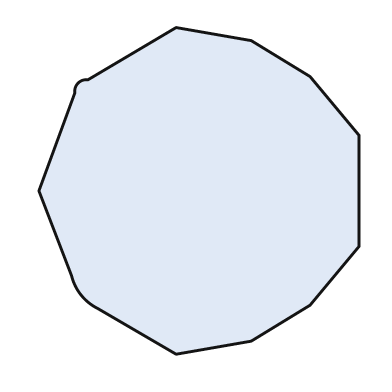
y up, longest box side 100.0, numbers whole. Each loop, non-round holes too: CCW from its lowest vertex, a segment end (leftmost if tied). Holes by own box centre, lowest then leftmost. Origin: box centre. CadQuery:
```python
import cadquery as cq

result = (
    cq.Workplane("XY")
    .moveTo(-7.0, -50.0)
    .lineTo(16.0, -46.0)
    .lineTo(34.0, -35.0)
    .lineTo(49.0, -17.0)
    .lineTo(49.0, 17.0)
    .lineTo(34.0, 35.0)
    .lineTo(16.0, 46.0)
    .lineTo(-7.0, 50.0)
    .lineTo(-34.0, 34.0)
    .threePointArc((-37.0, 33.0), (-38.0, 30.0))
    .lineTo(-49.0, 0.0)
    .lineTo(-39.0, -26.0)
    .threePointArc((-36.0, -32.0), (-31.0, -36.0))
    .close()
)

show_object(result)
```